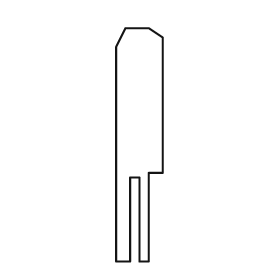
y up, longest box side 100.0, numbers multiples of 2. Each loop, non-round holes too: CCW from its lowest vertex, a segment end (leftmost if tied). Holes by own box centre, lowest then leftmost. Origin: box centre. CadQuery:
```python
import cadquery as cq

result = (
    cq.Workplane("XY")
    .moveTo(-10.0, -50.0)
    .lineTo(-4.0, -50.0)
    .lineTo(-4.0, -14.0)
    .lineTo(0.0, -14.0)
    .lineTo(0.0, -50.0)
    .lineTo(4.0, -50.0)
    .lineTo(4.0, -12.0)
    .lineTo(10.0, -12.0)
    .lineTo(10.0, 46.0)
    .lineTo(4.0, 50.0)
    .lineTo(-6.0, 50.0)
    .lineTo(-10.0, 42.0)
    .close()
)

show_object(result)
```